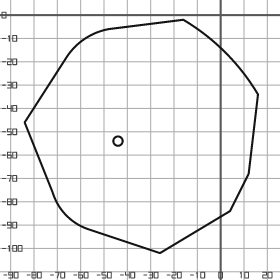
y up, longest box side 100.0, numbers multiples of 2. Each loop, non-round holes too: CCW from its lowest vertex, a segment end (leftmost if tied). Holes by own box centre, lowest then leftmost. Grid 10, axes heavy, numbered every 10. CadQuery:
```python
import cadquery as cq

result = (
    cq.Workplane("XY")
    .moveTo(-26.0, -102.0)
    .lineTo(4.0, -84.0)
    .lineTo(12.0, -68.0)
    .lineTo(16.0, -34.0)
    .threePointArc((2.0, -16.0), (-16.0, -2.0))
    .lineTo(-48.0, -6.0)
    .threePointArc((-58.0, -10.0), (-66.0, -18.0))
    .lineTo(-84.0, -46.0)
    .lineTo(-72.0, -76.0)
    .threePointArc((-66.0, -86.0), (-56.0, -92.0))
    .close()
    .moveTo(-44.0, -54.0)
    .circle(2.0)
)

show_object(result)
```